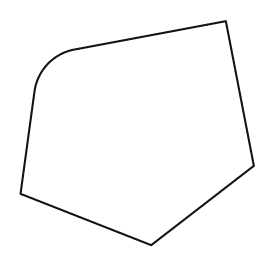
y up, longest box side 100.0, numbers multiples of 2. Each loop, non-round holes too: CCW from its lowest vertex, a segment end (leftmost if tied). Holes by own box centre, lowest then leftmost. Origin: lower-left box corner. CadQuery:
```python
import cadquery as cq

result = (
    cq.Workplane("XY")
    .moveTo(56.0, 0.0)
    .lineTo(100.0, 34.0)
    .lineTo(88.0, 96.0)
    .lineTo(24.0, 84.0)
    .threePointArc((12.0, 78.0), (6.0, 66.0))
    .lineTo(0.0, 22.0)
    .close()
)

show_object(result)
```